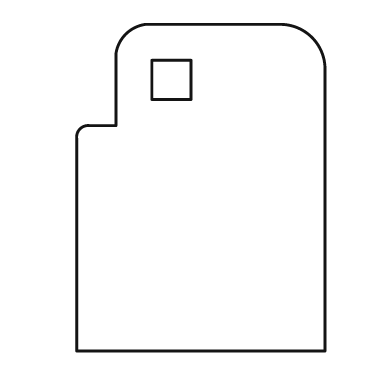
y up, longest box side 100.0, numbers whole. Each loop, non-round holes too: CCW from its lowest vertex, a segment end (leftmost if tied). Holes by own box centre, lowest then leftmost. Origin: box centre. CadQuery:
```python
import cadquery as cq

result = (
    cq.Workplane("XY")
    .moveTo(-38.0, -50.0)
    .lineTo(38.0, -50.0)
    .lineTo(38.0, 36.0)
    .threePointArc((34.0, 46.0), (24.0, 50.0))
    .lineTo(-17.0, 50.0)
    .threePointArc((-23.0, 47.0), (-26.0, 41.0))
    .lineTo(-26.0, 19.0)
    .lineTo(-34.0, 19.0)
    .threePointArc((-37.0, 18.0), (-38.0, 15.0))
    .close()
    .moveTo(-15.0, 27.0)
    .lineTo(-3.0, 27.0)
    .lineTo(-3.0, 39.0)
    .lineTo(-15.0, 39.0)
    .close()
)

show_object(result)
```